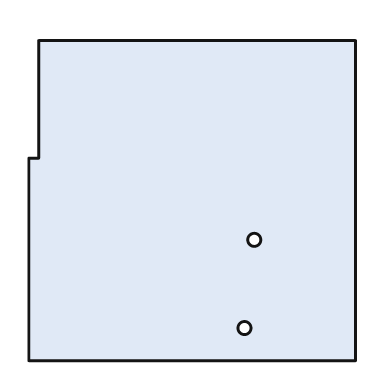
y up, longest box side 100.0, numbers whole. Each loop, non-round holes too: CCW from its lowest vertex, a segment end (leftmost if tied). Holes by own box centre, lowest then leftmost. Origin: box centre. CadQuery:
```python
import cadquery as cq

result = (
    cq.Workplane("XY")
    .moveTo(-50.0, -49.0)
    .lineTo(50.0, -49.0)
    .lineTo(50.0, 49.0)
    .lineTo(-47.0, 49.0)
    .lineTo(-47.0, 13.0)
    .lineTo(-50.0, 13.0)
    .close()
    .moveTo(16.0, -39.0)
    .circle(2.0)
    .moveTo(19.0, -12.0)
    .circle(2.0)
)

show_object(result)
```